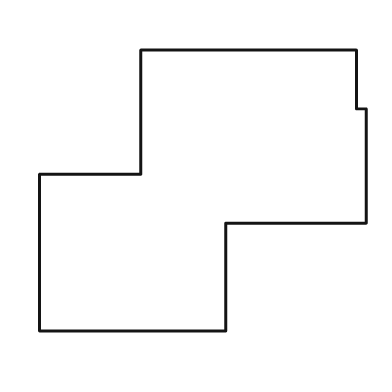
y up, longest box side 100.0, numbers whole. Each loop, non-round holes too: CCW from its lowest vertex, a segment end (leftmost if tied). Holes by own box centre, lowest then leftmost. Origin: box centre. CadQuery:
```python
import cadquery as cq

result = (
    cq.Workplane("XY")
    .moveTo(-50.0, -43.0)
    .lineTo(7.0, -43.0)
    .lineTo(7.0, -10.0)
    .lineTo(50.0, -10.0)
    .lineTo(50.0, 25.0)
    .lineTo(47.0, 25.0)
    .lineTo(47.0, 43.0)
    .lineTo(-19.0, 43.0)
    .lineTo(-19.0, 5.0)
    .lineTo(-50.0, 5.0)
    .close()
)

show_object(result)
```